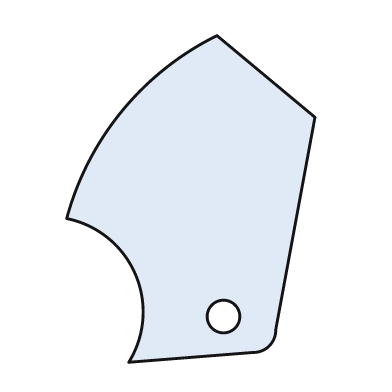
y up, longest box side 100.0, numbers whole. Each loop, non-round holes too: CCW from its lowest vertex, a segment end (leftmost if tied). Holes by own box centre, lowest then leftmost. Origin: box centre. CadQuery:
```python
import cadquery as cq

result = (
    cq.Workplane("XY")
    .moveTo(-19.0, -50.0)
    .lineTo(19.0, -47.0)
    .threePointArc((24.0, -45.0), (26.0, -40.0))
    .lineTo(38.0, 25.0)
    .lineTo(8.0, 50.0)
    .threePointArc((-21.0, 27.0), (-38.0, -6.0))
    .threePointArc((-17.0, -23.0), (-19.0, -50.0))
    .close()
    .moveTo(10.0, -36.0)
    .circle(5.0)
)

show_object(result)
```